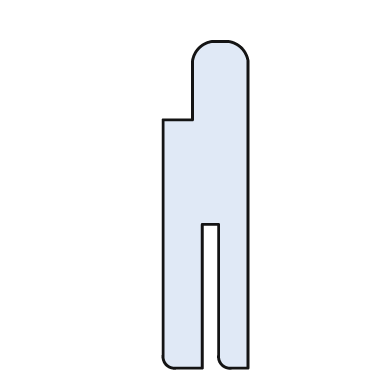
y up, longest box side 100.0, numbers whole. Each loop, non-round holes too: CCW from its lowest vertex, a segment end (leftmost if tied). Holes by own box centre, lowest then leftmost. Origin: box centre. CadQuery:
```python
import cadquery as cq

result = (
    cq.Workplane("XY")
    .moveTo(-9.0, -50.0)
    .lineTo(-1.0, -50.0)
    .lineTo(-1.0, -6.0)
    .lineTo(4.0, -6.0)
    .lineTo(4.0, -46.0)
    .threePointArc((5.0, -49.0), (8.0, -50.0))
    .lineTo(13.0, -50.0)
    .lineTo(13.0, 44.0)
    .threePointArc((11.0, 48.0), (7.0, 50.0))
    .lineTo(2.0, 50.0)
    .threePointArc((-2.0, 48.0), (-4.0, 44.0))
    .lineTo(-4.0, 26.0)
    .lineTo(-13.0, 26.0)
    .lineTo(-13.0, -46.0)
    .threePointArc((-12.0, -49.0), (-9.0, -50.0))
    .close()
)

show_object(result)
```